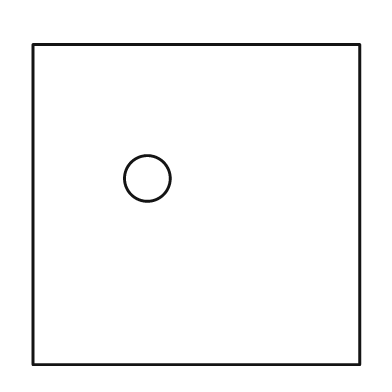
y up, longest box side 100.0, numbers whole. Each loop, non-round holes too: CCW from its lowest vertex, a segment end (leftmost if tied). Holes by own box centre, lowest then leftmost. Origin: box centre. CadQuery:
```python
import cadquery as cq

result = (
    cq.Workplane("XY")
    .moveTo(-50.0, -49.0)
    .lineTo(50.0, -49.0)
    .lineTo(50.0, 49.0)
    .lineTo(-50.0, 49.0)
    .close()
    .moveTo(-15.0, 8.0)
    .circle(7.0)
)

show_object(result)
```